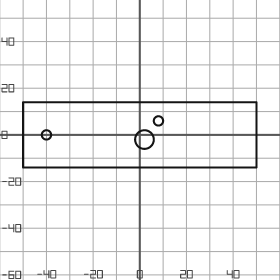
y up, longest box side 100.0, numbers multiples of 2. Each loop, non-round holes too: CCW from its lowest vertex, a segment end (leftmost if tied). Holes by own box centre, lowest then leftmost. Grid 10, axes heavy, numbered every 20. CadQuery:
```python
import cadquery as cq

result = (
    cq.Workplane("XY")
    .moveTo(-50.0, -14.0)
    .lineTo(50.0, -14.0)
    .lineTo(50.0, 14.0)
    .lineTo(-50.0, 14.0)
    .close()
    .moveTo(2.0, -2.0)
    .circle(4.0)
    .moveTo(-40.0, 0.0)
    .circle(2.0)
    .moveTo(8.0, 6.0)
    .circle(2.0)
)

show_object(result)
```